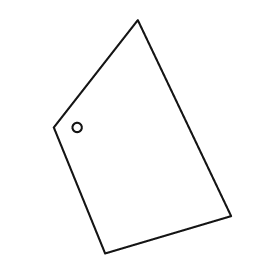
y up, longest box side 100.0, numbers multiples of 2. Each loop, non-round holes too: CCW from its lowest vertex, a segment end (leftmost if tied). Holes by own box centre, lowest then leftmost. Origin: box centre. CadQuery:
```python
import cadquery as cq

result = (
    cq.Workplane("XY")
    .moveTo(-16.0, -50.0)
    .lineTo(38.0, -34.0)
    .lineTo(-2.0, 50.0)
    .lineTo(-38.0, 4.0)
    .close()
    .moveTo(-28.0, 4.0)
    .circle(2.0)
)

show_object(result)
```